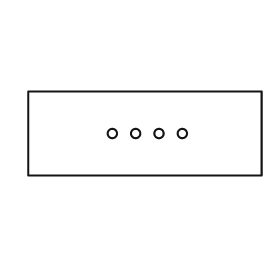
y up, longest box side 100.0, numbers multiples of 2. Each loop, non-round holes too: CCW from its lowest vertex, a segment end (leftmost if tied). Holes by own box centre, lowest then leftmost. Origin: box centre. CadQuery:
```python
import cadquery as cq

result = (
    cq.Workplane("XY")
    .moveTo(-50.0, -18.0)
    .lineTo(50.0, -18.0)
    .lineTo(50.0, 18.0)
    .lineTo(-50.0, 18.0)
    .close()
    .moveTo(-14.0, 0.0)
    .circle(2.0)
    .moveTo(-4.0, 0.0)
    .circle(2.0)
    .moveTo(6.0, 0.0)
    .circle(2.0)
    .moveTo(16.0, 0.0)
    .circle(2.0)
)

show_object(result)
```